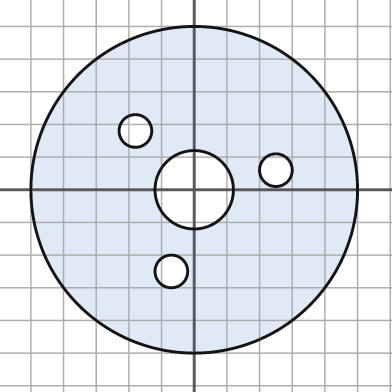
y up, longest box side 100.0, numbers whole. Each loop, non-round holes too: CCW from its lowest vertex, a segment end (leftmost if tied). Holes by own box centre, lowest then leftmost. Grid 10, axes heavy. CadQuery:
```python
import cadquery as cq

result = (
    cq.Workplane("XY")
    .moveTo(0.0, 0.0)
    .circle(50.0)
    .moveTo(-7.0, -25.0)
    .circle(5.0)
    .moveTo(0.0, 0.0)
    .circle(12.0)
    .moveTo(25.0, 6.0)
    .circle(5.0)
    .moveTo(-18.0, 18.0)
    .circle(5.0)
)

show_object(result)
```